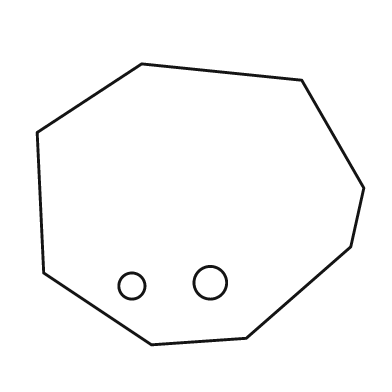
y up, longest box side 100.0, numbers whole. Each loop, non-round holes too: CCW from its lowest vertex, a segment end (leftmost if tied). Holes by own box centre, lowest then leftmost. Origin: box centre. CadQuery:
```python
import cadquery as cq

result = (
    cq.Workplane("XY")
    .moveTo(-15.0, -43.0)
    .lineTo(14.0, -41.0)
    .lineTo(46.0, -13.0)
    .lineTo(50.0, 5.0)
    .lineTo(31.0, 38.0)
    .lineTo(-18.0, 43.0)
    .lineTo(-50.0, 22.0)
    .lineTo(-48.0, -21.0)
    .close()
    .moveTo(-21.0, -25.0)
    .circle(4.0)
    .moveTo(3.0, -24.0)
    .circle(5.0)
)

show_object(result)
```